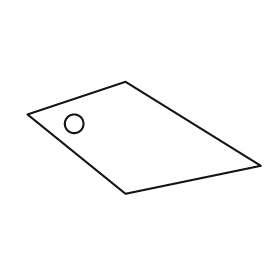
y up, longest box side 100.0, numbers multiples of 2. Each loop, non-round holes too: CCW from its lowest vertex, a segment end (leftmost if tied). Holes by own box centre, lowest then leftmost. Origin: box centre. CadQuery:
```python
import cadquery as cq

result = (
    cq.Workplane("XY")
    .moveTo(-8.0, -24.0)
    .lineTo(50.0, -12.0)
    .lineTo(-8.0, 24.0)
    .lineTo(-50.0, 10.0)
    .close()
    .moveTo(-30.0, 6.0)
    .circle(4.0)
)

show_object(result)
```